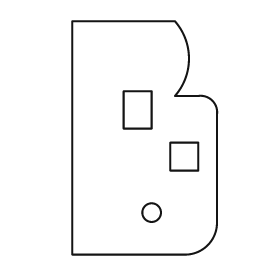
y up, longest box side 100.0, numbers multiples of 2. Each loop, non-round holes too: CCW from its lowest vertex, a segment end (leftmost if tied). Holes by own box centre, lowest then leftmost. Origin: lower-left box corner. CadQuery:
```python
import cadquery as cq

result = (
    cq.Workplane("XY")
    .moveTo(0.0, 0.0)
    .lineTo(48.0, 0.0)
    .threePointArc((58.0, 4.0), (62.0, 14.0))
    .lineTo(62.0, 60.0)
    .threePointArc((60.0, 66.0), (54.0, 68.0))
    .lineTo(44.0, 68.0)
    .threePointArc((50.0, 84.0), (44.0, 100.0))
    .lineTo(0.0, 100.0)
    .close()
    .moveTo(34.0, 18.0)
    .circle(4.0)
    .moveTo(42.0, 36.0)
    .lineTo(54.0, 36.0)
    .lineTo(54.0, 48.0)
    .lineTo(42.0, 48.0)
    .close()
    .moveTo(22.0, 54.0)
    .lineTo(34.0, 54.0)
    .lineTo(34.0, 70.0)
    .lineTo(22.0, 70.0)
    .close()
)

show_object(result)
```